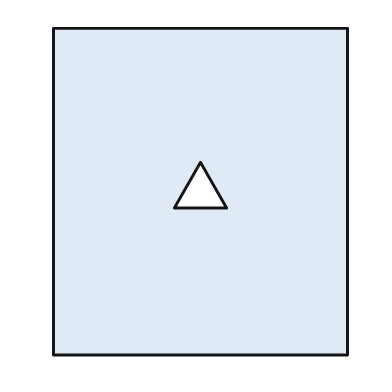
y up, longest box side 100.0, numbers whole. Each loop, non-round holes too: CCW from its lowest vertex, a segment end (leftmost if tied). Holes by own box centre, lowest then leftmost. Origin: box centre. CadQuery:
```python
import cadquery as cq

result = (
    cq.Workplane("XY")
    .moveTo(-45.0, -50.0)
    .lineTo(45.0, -50.0)
    .lineTo(45.0, 50.0)
    .lineTo(-45.0, 50.0)
    .close()
    .moveTo(-8.0, -5.0)
    .lineTo(8.0, -5.0)
    .lineTo(0.0, 9.0)
    .close()
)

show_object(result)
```